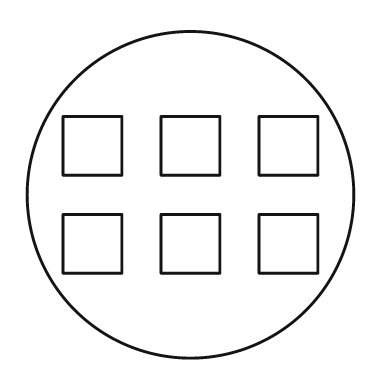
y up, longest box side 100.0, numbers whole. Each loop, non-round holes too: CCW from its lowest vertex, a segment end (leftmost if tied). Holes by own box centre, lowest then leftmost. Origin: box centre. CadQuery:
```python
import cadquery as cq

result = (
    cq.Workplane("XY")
    .moveTo(0.0, 0.0)
    .circle(50.0)
    .moveTo(-39.0, -24.0)
    .lineTo(-21.0, -24.0)
    .lineTo(-21.0, -6.0)
    .lineTo(-39.0, -6.0)
    .close()
    .moveTo(-9.0, -24.0)
    .lineTo(9.0, -24.0)
    .lineTo(9.0, -6.0)
    .lineTo(-9.0, -6.0)
    .close()
    .moveTo(21.0, -24.0)
    .lineTo(39.0, -24.0)
    .lineTo(39.0, -6.0)
    .lineTo(21.0, -6.0)
    .close()
    .moveTo(-39.0, 6.0)
    .lineTo(-21.0, 6.0)
    .lineTo(-21.0, 24.0)
    .lineTo(-39.0, 24.0)
    .close()
    .moveTo(-9.0, 6.0)
    .lineTo(9.0, 6.0)
    .lineTo(9.0, 24.0)
    .lineTo(-9.0, 24.0)
    .close()
    .moveTo(21.0, 6.0)
    .lineTo(39.0, 6.0)
    .lineTo(39.0, 24.0)
    .lineTo(21.0, 24.0)
    .close()
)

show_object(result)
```